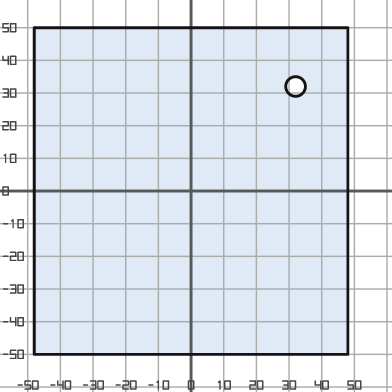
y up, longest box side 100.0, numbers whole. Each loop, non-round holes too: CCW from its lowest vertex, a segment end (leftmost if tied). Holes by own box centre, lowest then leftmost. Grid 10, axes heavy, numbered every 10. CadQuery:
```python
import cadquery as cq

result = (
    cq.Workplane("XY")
    .moveTo(-48.0, -50.0)
    .lineTo(48.0, -50.0)
    .lineTo(48.0, 50.0)
    .lineTo(-48.0, 50.0)
    .close()
    .moveTo(32.0, 32.0)
    .circle(3.0)
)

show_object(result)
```